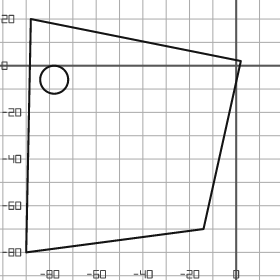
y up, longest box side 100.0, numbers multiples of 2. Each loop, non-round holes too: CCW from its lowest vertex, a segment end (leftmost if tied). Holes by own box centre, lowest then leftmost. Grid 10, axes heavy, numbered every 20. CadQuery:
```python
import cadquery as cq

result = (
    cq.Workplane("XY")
    .moveTo(-90.0, -80.0)
    .lineTo(-14.0, -70.0)
    .lineTo(2.0, 2.0)
    .lineTo(-88.0, 20.0)
    .close()
    .moveTo(-78.0, -6.0)
    .circle(6.0)
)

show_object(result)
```